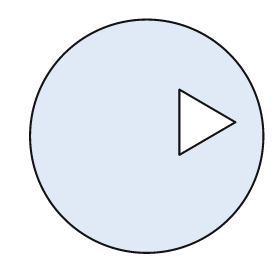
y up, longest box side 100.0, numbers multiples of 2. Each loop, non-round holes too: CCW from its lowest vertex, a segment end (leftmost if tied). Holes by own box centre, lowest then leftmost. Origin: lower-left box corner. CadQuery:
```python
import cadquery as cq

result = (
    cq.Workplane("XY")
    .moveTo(50.0, 50.0)
    .circle(50.0)
    .moveTo(64.0, 42.0)
    .lineTo(88.0, 56.0)
    .lineTo(64.0, 70.0)
    .close()
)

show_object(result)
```